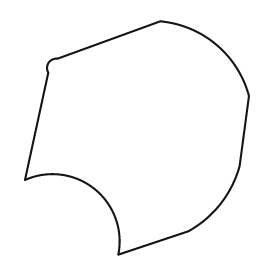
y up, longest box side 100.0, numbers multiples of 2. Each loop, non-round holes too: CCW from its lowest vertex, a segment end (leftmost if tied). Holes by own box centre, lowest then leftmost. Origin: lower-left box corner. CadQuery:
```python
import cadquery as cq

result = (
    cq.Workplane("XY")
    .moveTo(40.0, 0.0)
    .lineTo(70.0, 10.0)
    .threePointArc((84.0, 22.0), (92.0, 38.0))
    .lineTo(96.0, 68.0)
    .threePointArc((82.0, 90.0), (58.0, 100.0))
    .lineTo(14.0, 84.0)
    .threePointArc((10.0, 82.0), (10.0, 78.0))
    .lineTo(0.0, 32.0)
    .threePointArc((30.0, 28.0), (40.0, 0.0))
    .close()
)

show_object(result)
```